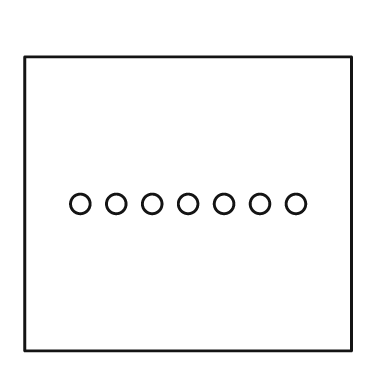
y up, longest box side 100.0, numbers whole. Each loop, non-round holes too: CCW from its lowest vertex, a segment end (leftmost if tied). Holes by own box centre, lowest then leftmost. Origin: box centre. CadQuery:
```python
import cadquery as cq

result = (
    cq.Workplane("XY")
    .moveTo(-50.0, -45.0)
    .lineTo(50.0, -45.0)
    .lineTo(50.0, 45.0)
    .lineTo(-50.0, 45.0)
    .close()
    .moveTo(-33.0, 0.0)
    .circle(3.0)
    .moveTo(-22.0, 0.0)
    .circle(3.0)
    .moveTo(-11.0, 0.0)
    .circle(3.0)
    .moveTo(0.0, 0.0)
    .circle(3.0)
    .moveTo(11.0, 0.0)
    .circle(3.0)
    .moveTo(22.0, 0.0)
    .circle(3.0)
    .moveTo(33.0, 0.0)
    .circle(3.0)
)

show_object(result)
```